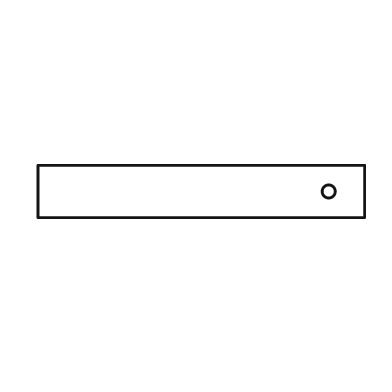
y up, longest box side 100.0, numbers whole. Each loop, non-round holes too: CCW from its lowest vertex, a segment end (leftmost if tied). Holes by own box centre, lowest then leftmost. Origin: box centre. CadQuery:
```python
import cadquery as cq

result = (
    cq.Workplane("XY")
    .moveTo(-50.0, -8.0)
    .lineTo(50.0, -8.0)
    .lineTo(50.0, 8.0)
    .lineTo(-50.0, 8.0)
    .close()
    .moveTo(39.0, 0.0)
    .circle(2.0)
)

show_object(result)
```